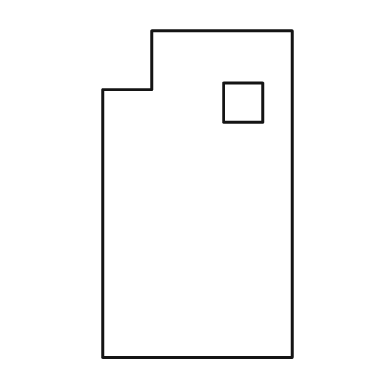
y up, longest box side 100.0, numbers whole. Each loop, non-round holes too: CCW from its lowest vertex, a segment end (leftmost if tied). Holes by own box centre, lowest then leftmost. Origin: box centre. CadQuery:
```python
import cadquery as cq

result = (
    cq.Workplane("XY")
    .moveTo(-29.0, -50.0)
    .lineTo(29.0, -50.0)
    .lineTo(29.0, 50.0)
    .lineTo(-14.0, 50.0)
    .lineTo(-14.0, 32.0)
    .lineTo(-29.0, 32.0)
    .close()
    .moveTo(8.0, 22.0)
    .lineTo(20.0, 22.0)
    .lineTo(20.0, 34.0)
    .lineTo(8.0, 34.0)
    .close()
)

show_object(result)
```